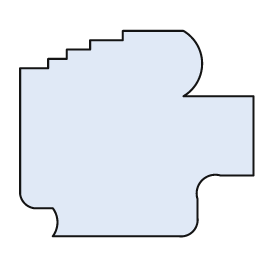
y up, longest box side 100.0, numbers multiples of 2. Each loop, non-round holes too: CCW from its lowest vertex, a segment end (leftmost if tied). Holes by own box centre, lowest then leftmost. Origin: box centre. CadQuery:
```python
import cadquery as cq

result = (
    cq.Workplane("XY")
    .moveTo(-36.0, -44.0)
    .lineTo(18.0, -44.0)
    .threePointArc((24.0, -42.0), (26.0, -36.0))
    .lineTo(26.0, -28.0)
    .threePointArc((28.0, -20.0), (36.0, -18.0))
    .lineTo(50.0, -18.0)
    .lineTo(50.0, 16.0)
    .lineTo(20.0, 16.0)
    .threePointArc((28.0, 30.0), (20.0, 44.0))
    .lineTo(-6.0, 44.0)
    .lineTo(-6.0, 40.0)
    .lineTo(-20.0, 40.0)
    .lineTo(-20.0, 36.0)
    .lineTo(-30.0, 36.0)
    .lineTo(-30.0, 32.0)
    .lineTo(-38.0, 32.0)
    .lineTo(-38.0, 28.0)
    .lineTo(-50.0, 28.0)
    .lineTo(-50.0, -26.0)
    .threePointArc((-48.0, -30.0), (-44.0, -32.0))
    .lineTo(-36.0, -32.0)
    .threePointArc((-34.0, -38.0), (-36.0, -44.0))
    .close()
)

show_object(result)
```